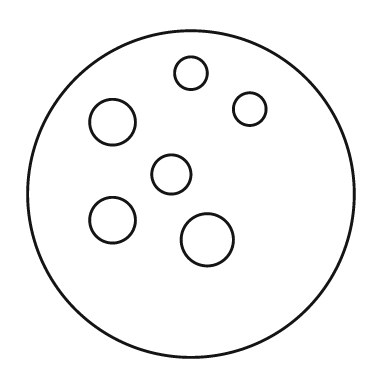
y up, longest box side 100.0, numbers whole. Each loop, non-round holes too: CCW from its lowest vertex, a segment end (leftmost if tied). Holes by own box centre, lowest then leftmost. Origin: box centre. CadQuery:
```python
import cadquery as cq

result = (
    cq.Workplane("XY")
    .moveTo(0.0, 0.0)
    .circle(50.0)
    .moveTo(5.0, -14.0)
    .circle(8.0)
    .moveTo(-24.0, -8.0)
    .circle(7.0)
    .moveTo(-6.0, 6.0)
    .circle(6.0)
    .moveTo(-24.0, 22.0)
    .circle(7.0)
    .moveTo(18.0, 26.0)
    .circle(5.0)
    .moveTo(0.0, 37.0)
    .circle(5.0)
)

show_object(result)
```